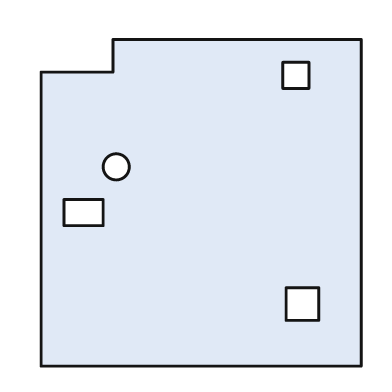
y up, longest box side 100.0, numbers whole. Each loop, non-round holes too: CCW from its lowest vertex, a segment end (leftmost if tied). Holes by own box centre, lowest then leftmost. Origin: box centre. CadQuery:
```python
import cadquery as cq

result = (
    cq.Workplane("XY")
    .moveTo(-49.0, -50.0)
    .lineTo(49.0, -50.0)
    .lineTo(49.0, 50.0)
    .lineTo(-27.0, 50.0)
    .lineTo(-27.0, 40.0)
    .lineTo(-49.0, 40.0)
    .close()
    .moveTo(26.0, -36.0)
    .lineTo(36.0, -36.0)
    .lineTo(36.0, -26.0)
    .lineTo(26.0, -26.0)
    .close()
    .moveTo(-42.0, -7.0)
    .lineTo(-30.0, -7.0)
    .lineTo(-30.0, 1.0)
    .lineTo(-42.0, 1.0)
    .close()
    .moveTo(-26.0, 11.0)
    .circle(4.0)
    .moveTo(25.0, 35.0)
    .lineTo(33.0, 35.0)
    .lineTo(33.0, 43.0)
    .lineTo(25.0, 43.0)
    .close()
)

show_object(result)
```